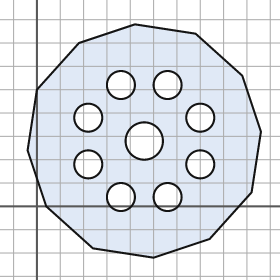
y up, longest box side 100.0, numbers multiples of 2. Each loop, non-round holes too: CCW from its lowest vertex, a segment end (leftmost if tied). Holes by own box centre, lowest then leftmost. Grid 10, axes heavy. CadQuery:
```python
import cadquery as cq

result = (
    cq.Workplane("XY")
    .moveTo(50.0, -22.0)
    .lineTo(74.0, -14.0)
    .lineTo(92.0, 6.0)
    .lineTo(96.0, 32.0)
    .lineTo(88.0, 56.0)
    .lineTo(68.0, 74.0)
    .lineTo(42.0, 78.0)
    .lineTo(18.0, 70.0)
    .lineTo(0.0, 50.0)
    .lineTo(-4.0, 24.0)
    .lineTo(4.0, 0.0)
    .lineTo(24.0, -18.0)
    .close()
    .moveTo(36.0, 4.0)
    .circle(6.0)
    .moveTo(56.0, 4.0)
    .circle(6.0)
    .moveTo(22.0, 18.0)
    .circle(6.0)
    .moveTo(70.0, 18.0)
    .circle(6.0)
    .moveTo(46.0, 28.0)
    .circle(8.0)
    .moveTo(22.0, 38.0)
    .circle(6.0)
    .moveTo(70.0, 38.0)
    .circle(6.0)
    .moveTo(36.0, 52.0)
    .circle(6.0)
    .moveTo(56.0, 52.0)
    .circle(6.0)
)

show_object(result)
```